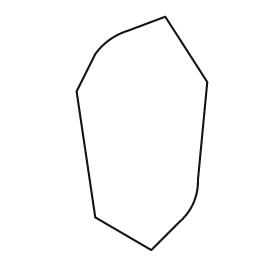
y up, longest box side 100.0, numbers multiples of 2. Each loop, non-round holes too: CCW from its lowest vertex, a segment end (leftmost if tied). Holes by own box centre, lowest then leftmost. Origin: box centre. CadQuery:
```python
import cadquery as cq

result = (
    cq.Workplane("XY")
    .moveTo(4.0, -50.0)
    .lineTo(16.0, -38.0)
    .threePointArc((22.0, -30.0), (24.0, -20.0))
    .lineTo(28.0, 22.0)
    .lineTo(10.0, 50.0)
    .lineTo(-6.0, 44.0)
    .threePointArc((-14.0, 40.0), (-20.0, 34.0))
    .lineTo(-28.0, 18.0)
    .lineTo(-20.0, -36.0)
    .close()
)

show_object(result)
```